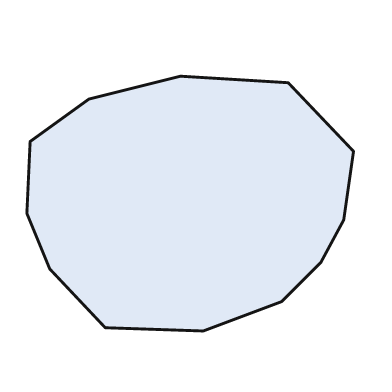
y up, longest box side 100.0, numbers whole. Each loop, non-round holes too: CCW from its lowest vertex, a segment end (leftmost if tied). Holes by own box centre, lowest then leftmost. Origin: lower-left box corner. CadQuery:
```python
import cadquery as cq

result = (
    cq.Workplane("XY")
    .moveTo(54.0, 0.0)
    .lineTo(78.0, 9.0)
    .lineTo(90.0, 21.0)
    .lineTo(97.0, 34.0)
    .lineTo(100.0, 55.0)
    .lineTo(80.0, 76.0)
    .lineTo(47.0, 78.0)
    .lineTo(19.0, 71.0)
    .lineTo(1.0, 58.0)
    .lineTo(0.0, 36.0)
    .lineTo(7.0, 19.0)
    .lineTo(24.0, 1.0)
    .close()
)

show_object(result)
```